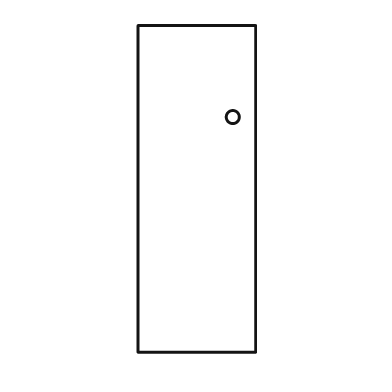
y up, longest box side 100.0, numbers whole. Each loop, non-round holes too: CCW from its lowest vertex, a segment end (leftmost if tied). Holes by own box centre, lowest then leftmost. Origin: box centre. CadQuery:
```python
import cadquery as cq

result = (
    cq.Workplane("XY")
    .moveTo(-18.0, -50.0)
    .lineTo(18.0, -50.0)
    .lineTo(18.0, 50.0)
    .lineTo(-18.0, 50.0)
    .close()
    .moveTo(11.0, 22.0)
    .circle(2.0)
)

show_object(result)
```